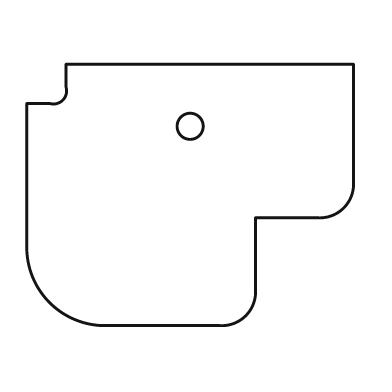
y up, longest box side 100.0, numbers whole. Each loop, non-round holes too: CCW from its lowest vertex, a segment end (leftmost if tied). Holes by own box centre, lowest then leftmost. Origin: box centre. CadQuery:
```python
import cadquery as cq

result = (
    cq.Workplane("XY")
    .moveTo(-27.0, -40.0)
    .lineTo(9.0, -40.0)
    .threePointArc((17.0, -37.0), (20.0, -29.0))
    .lineTo(20.0, -7.0)
    .lineTo(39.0, -7.0)
    .threePointArc((47.0, -4.0), (50.0, 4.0))
    .lineTo(50.0, 40.0)
    .lineTo(-38.0, 40.0)
    .lineTo(-38.0, 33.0)
    .threePointArc((-39.0, 29.0), (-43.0, 28.0))
    .lineTo(-50.0, 28.0)
    .lineTo(-50.0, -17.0)
    .threePointArc((-43.0, -33.0), (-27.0, -40.0))
    .close()
    .moveTo(0.0, 21.0)
    .circle(4.0)
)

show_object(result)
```